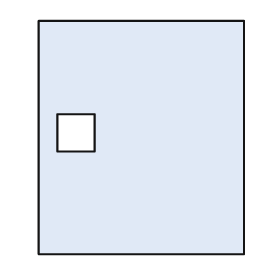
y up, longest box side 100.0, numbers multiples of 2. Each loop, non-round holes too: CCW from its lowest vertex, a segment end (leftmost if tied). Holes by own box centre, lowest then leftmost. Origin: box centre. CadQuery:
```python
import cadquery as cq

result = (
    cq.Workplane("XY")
    .moveTo(-44.0, -50.0)
    .lineTo(44.0, -50.0)
    .lineTo(44.0, 50.0)
    .lineTo(-44.0, 50.0)
    .close()
    .moveTo(-36.0, -6.0)
    .lineTo(-20.0, -6.0)
    .lineTo(-20.0, 10.0)
    .lineTo(-36.0, 10.0)
    .close()
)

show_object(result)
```